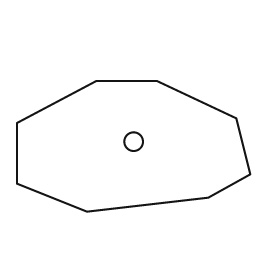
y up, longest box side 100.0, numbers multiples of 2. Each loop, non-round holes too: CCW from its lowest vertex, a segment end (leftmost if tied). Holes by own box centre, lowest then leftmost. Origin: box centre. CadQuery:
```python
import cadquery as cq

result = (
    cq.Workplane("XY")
    .moveTo(-20.0, -28.0)
    .lineTo(32.0, -22.0)
    .lineTo(50.0, -12.0)
    .lineTo(44.0, 12.0)
    .lineTo(10.0, 28.0)
    .lineTo(-16.0, 28.0)
    .lineTo(-50.0, 10.0)
    .lineTo(-50.0, -16.0)
    .close()
    .moveTo(0.0, 2.0)
    .circle(4.0)
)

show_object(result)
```